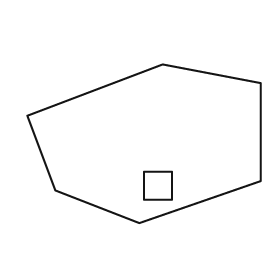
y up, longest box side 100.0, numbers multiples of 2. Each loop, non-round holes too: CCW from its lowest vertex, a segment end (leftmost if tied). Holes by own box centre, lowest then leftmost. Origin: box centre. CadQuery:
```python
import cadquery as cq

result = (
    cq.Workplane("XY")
    .moveTo(-2.0, -34.0)
    .lineTo(50.0, -16.0)
    .lineTo(50.0, 26.0)
    .lineTo(8.0, 34.0)
    .lineTo(-50.0, 12.0)
    .lineTo(-38.0, -20.0)
    .close()
    .moveTo(0.0, -24.0)
    .lineTo(12.0, -24.0)
    .lineTo(12.0, -12.0)
    .lineTo(0.0, -12.0)
    .close()
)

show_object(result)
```